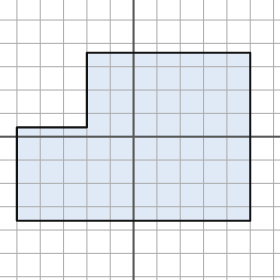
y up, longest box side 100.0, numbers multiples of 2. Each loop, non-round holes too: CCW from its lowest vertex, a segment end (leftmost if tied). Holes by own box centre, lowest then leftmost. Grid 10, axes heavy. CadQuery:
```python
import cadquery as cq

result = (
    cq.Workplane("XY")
    .moveTo(-50.0, -36.0)
    .lineTo(50.0, -36.0)
    .lineTo(50.0, 36.0)
    .lineTo(-20.0, 36.0)
    .lineTo(-20.0, 4.0)
    .lineTo(-50.0, 4.0)
    .close()
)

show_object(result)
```